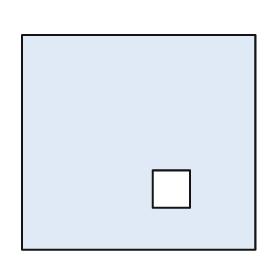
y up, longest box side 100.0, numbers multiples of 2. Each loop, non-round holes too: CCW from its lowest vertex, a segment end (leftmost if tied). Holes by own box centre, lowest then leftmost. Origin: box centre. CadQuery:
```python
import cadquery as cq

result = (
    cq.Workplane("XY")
    .moveTo(-50.0, -46.0)
    .lineTo(50.0, -46.0)
    .lineTo(50.0, 46.0)
    .lineTo(-50.0, 46.0)
    .close()
    .moveTo(6.0, -28.0)
    .lineTo(22.0, -28.0)
    .lineTo(22.0, -12.0)
    .lineTo(6.0, -12.0)
    .close()
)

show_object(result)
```